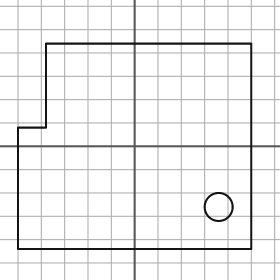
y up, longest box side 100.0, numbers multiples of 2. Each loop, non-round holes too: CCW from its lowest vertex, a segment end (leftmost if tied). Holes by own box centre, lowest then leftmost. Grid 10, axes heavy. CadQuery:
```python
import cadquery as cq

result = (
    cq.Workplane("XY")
    .moveTo(-50.0, -44.0)
    .lineTo(50.0, -44.0)
    .lineTo(50.0, 44.0)
    .lineTo(-38.0, 44.0)
    .lineTo(-38.0, 8.0)
    .lineTo(-50.0, 8.0)
    .close()
    .moveTo(36.0, -26.0)
    .circle(6.0)
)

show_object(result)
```